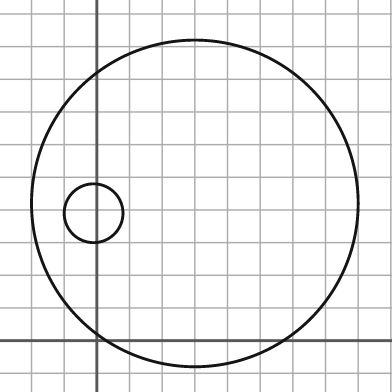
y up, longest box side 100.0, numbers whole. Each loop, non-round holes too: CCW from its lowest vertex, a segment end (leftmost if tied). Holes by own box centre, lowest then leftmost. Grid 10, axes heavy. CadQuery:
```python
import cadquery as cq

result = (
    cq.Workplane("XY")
    .moveTo(30.0, 42.0)
    .circle(50.0)
    .moveTo(-1.0, 39.0)
    .circle(9.0)
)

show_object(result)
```